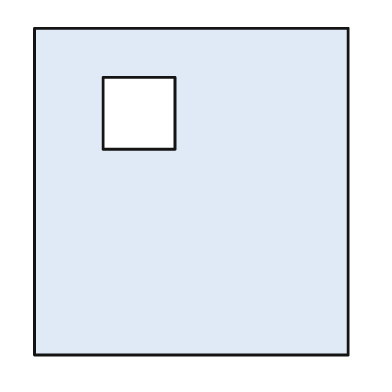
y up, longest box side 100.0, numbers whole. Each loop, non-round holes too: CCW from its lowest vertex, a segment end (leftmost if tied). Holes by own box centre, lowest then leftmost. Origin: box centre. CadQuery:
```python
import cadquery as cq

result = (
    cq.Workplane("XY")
    .moveTo(-48.0, -50.0)
    .lineTo(48.0, -50.0)
    .lineTo(48.0, 50.0)
    .lineTo(-48.0, 50.0)
    .close()
    .moveTo(-27.0, 13.0)
    .lineTo(-5.0, 13.0)
    .lineTo(-5.0, 35.0)
    .lineTo(-27.0, 35.0)
    .close()
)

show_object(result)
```